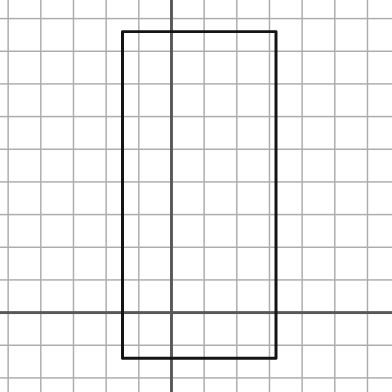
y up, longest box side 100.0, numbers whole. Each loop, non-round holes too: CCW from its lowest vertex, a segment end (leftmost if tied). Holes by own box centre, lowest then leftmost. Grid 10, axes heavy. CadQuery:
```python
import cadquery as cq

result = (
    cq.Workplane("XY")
    .moveTo(-15.0, -14.0)
    .lineTo(32.0, -14.0)
    .lineTo(32.0, 86.0)
    .lineTo(-15.0, 86.0)
    .close()
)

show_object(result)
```